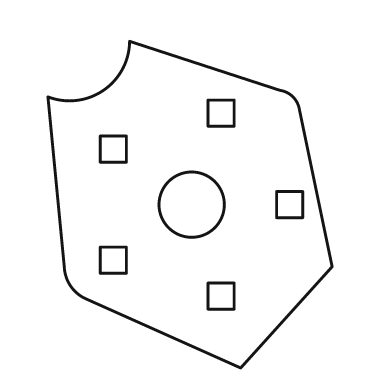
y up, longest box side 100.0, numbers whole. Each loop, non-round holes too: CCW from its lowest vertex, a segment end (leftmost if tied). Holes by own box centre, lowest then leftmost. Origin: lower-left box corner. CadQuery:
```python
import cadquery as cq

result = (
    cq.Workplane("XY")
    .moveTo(59.0, 0.0)
    .lineTo(87.0, 31.0)
    .lineTo(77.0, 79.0)
    .threePointArc((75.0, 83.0), (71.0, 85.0))
    .lineTo(25.0, 100.0)
    .threePointArc((17.0, 85.0), (0.0, 83.0))
    .lineTo(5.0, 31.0)
    .threePointArc((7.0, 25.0), (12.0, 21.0))
    .close()
    .moveTo(49.0, 18.0)
    .lineTo(57.0, 18.0)
    .lineTo(57.0, 26.0)
    .lineTo(49.0, 26.0)
    .close()
    .moveTo(16.0, 29.0)
    .lineTo(24.0, 29.0)
    .lineTo(24.0, 37.0)
    .lineTo(16.0, 37.0)
    .close()
    .moveTo(44.0, 50.0)
    .circle(10.0)
    .moveTo(70.0, 46.0)
    .lineTo(78.0, 46.0)
    .lineTo(78.0, 54.0)
    .lineTo(70.0, 54.0)
    .close()
    .moveTo(16.0, 63.0)
    .lineTo(24.0, 63.0)
    .lineTo(24.0, 71.0)
    .lineTo(16.0, 71.0)
    .close()
    .moveTo(49.0, 74.0)
    .lineTo(57.0, 74.0)
    .lineTo(57.0, 82.0)
    .lineTo(49.0, 82.0)
    .close()
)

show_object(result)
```